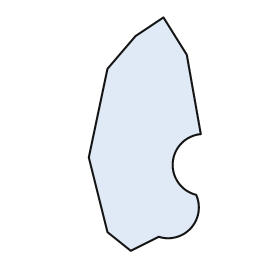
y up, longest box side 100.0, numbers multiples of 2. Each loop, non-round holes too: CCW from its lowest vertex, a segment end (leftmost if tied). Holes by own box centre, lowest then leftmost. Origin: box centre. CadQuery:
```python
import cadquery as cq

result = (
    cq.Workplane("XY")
    .moveTo(-6.0, -50.0)
    .lineTo(6.0, -44.0)
    .threePointArc((20.0, -40.0), (22.0, -26.0))
    .threePointArc((12.0, -12.0), (24.0, 0.0))
    .lineTo(18.0, 34.0)
    .lineTo(8.0, 50.0)
    .lineTo(-4.0, 42.0)
    .lineTo(-16.0, 28.0)
    .lineTo(-24.0, -10.0)
    .lineTo(-16.0, -42.0)
    .close()
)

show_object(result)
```